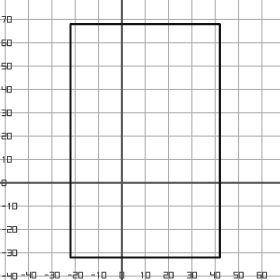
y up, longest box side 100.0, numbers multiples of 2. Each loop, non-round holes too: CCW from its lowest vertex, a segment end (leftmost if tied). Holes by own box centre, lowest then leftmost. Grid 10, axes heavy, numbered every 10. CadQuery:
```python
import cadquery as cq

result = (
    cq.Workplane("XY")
    .moveTo(-22.0, -32.0)
    .lineTo(42.0, -32.0)
    .lineTo(42.0, 68.0)
    .lineTo(-22.0, 68.0)
    .close()
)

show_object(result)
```